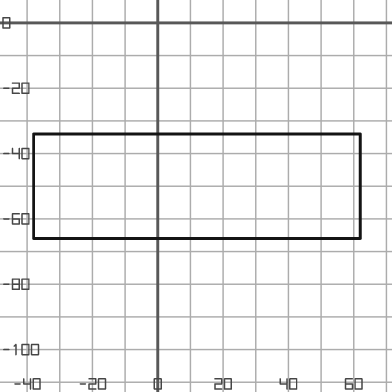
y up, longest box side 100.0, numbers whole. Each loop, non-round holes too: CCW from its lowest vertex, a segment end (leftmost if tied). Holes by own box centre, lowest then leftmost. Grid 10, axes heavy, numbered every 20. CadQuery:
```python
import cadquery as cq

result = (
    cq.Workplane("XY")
    .moveTo(-38.0, -66.0)
    .lineTo(62.0, -66.0)
    .lineTo(62.0, -34.0)
    .lineTo(-38.0, -34.0)
    .close()
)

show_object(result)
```